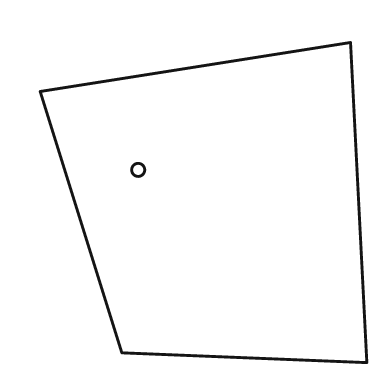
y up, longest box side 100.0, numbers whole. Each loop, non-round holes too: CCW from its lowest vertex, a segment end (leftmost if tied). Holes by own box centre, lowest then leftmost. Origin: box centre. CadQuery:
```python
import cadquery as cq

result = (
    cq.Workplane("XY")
    .moveTo(50.0, -49.0)
    .lineTo(45.0, 49.0)
    .lineTo(-50.0, 34.0)
    .lineTo(-25.0, -46.0)
    .close()
    .moveTo(-20.0, 10.0)
    .circle(2.0)
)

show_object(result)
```